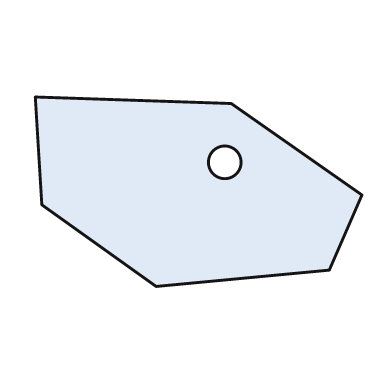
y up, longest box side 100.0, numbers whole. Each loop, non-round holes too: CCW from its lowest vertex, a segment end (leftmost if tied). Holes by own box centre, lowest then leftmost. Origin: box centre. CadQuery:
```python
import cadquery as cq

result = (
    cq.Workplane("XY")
    .moveTo(-13.0, -29.0)
    .lineTo(40.0, -24.0)
    .lineTo(50.0, -1.0)
    .lineTo(10.0, 27.0)
    .lineTo(-50.0, 29.0)
    .lineTo(-48.0, -4.0)
    .close()
    .moveTo(8.0, 9.0)
    .circle(5.0)
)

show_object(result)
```